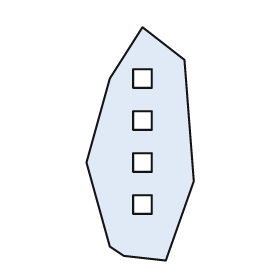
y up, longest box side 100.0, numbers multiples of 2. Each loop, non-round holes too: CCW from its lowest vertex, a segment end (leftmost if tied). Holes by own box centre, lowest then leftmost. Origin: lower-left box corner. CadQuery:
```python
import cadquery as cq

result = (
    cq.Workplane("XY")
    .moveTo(34.0, 0.0)
    .lineTo(46.0, 34.0)
    .lineTo(42.0, 86.0)
    .lineTo(24.0, 100.0)
    .lineTo(10.0, 78.0)
    .lineTo(0.0, 42.0)
    .lineTo(10.0, 6.0)
    .lineTo(16.0, 2.0)
    .close()
    .moveTo(20.0, 20.0)
    .lineTo(28.0, 20.0)
    .lineTo(28.0, 28.0)
    .lineTo(20.0, 28.0)
    .close()
    .moveTo(20.0, 38.0)
    .lineTo(28.0, 38.0)
    .lineTo(28.0, 46.0)
    .lineTo(20.0, 46.0)
    .close()
    .moveTo(20.0, 56.0)
    .lineTo(28.0, 56.0)
    .lineTo(28.0, 64.0)
    .lineTo(20.0, 64.0)
    .close()
    .moveTo(20.0, 74.0)
    .lineTo(28.0, 74.0)
    .lineTo(28.0, 82.0)
    .lineTo(20.0, 82.0)
    .close()
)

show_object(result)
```